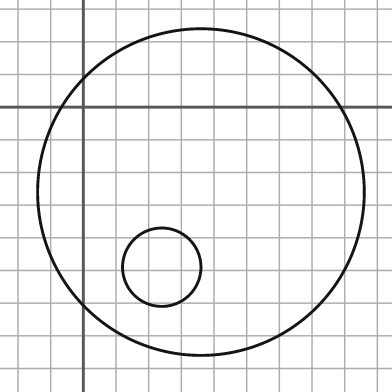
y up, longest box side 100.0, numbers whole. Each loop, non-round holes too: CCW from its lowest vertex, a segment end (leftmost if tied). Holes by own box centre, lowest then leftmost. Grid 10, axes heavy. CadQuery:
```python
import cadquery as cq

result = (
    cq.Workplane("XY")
    .moveTo(36.0, -26.0)
    .circle(50.0)
    .moveTo(24.0, -49.0)
    .circle(12.0)
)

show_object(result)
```